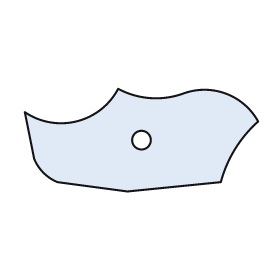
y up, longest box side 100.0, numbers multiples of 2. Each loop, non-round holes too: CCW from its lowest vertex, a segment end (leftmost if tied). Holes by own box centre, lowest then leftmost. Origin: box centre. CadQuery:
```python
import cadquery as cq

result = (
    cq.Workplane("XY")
    .moveTo(-6.0, -22.0)
    .lineTo(34.0, -18.0)
    .threePointArc((40.0, -4.0), (50.0, 8.0))
    .threePointArc((36.0, 20.0), (18.0, 20.0))
    .threePointArc((4.0, 18.0), (-10.0, 22.0))
    .threePointArc((-28.0, 8.0), (-50.0, 12.0))
    .lineTo(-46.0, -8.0)
    .threePointArc((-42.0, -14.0), (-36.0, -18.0))
    .close()
    .moveTo(0.0, 0.0)
    .circle(4.0)
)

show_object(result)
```